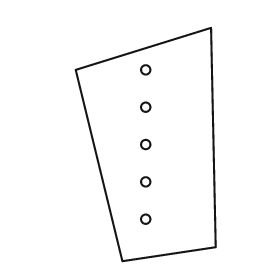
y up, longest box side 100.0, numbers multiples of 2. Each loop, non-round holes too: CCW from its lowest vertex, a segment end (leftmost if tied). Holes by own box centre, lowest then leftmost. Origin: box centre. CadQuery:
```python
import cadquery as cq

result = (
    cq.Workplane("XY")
    .moveTo(-10.0, -50.0)
    .lineTo(30.0, -44.0)
    .lineTo(28.0, 50.0)
    .lineTo(-30.0, 32.0)
    .close()
    .moveTo(0.0, -32.0)
    .circle(2.0)
    .moveTo(0.0, -16.0)
    .circle(2.0)
    .moveTo(0.0, 0.0)
    .circle(2.0)
    .moveTo(0.0, 16.0)
    .circle(2.0)
    .moveTo(0.0, 32.0)
    .circle(2.0)
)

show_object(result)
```